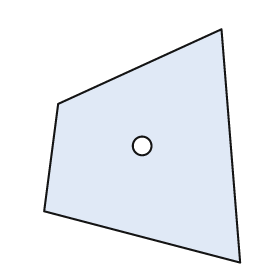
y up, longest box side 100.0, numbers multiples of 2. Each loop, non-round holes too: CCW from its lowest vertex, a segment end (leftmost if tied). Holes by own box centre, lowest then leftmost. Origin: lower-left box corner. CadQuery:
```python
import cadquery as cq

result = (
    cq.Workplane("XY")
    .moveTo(84.0, 0.0)
    .lineTo(76.0, 100.0)
    .lineTo(6.0, 68.0)
    .lineTo(0.0, 22.0)
    .close()
    .moveTo(42.0, 50.0)
    .circle(4.0)
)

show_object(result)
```